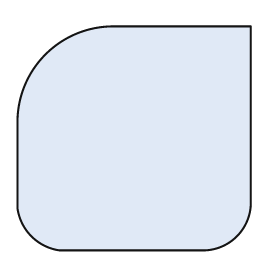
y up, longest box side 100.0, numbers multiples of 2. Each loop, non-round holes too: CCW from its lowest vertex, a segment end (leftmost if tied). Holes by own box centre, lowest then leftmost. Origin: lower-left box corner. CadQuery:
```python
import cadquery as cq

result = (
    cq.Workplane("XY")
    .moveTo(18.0, 0.0)
    .lineTo(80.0, 0.0)
    .threePointArc((94.0, 6.0), (100.0, 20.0))
    .lineTo(100.0, 96.0)
    .lineTo(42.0, 96.0)
    .threePointArc((12.0, 84.0), (0.0, 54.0))
    .lineTo(0.0, 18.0)
    .threePointArc((6.0, 6.0), (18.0, 0.0))
    .close()
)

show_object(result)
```